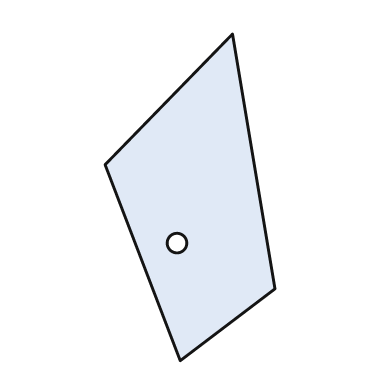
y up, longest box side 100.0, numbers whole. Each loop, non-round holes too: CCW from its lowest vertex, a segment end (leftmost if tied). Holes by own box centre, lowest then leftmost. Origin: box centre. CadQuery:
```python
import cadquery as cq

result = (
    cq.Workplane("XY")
    .moveTo(-3.0, -50.0)
    .lineTo(26.0, -28.0)
    .lineTo(13.0, 50.0)
    .lineTo(-26.0, 10.0)
    .close()
    .moveTo(-4.0, -14.0)
    .circle(3.0)
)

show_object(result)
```